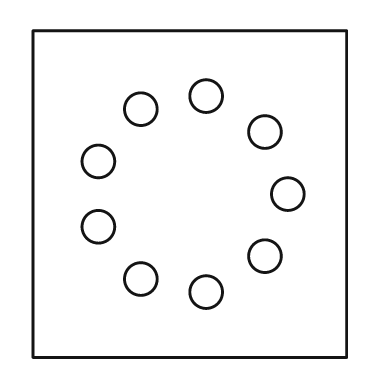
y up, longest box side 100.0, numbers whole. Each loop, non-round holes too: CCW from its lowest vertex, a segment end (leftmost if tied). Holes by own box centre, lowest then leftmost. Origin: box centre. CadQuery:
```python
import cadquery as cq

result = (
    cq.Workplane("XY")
    .moveTo(-48.0, -50.0)
    .lineTo(48.0, -50.0)
    .lineTo(48.0, 50.0)
    .lineTo(-48.0, 50.0)
    .close()
    .moveTo(5.0, -30.0)
    .circle(5.0)
    .moveTo(-15.0, -26.0)
    .circle(5.0)
    .moveTo(23.0, -19.0)
    .circle(5.0)
    .moveTo(-28.0, -10.0)
    .circle(5.0)
    .moveTo(30.0, 0.0)
    .circle(5.0)
    .moveTo(-28.0, 10.0)
    .circle(5.0)
    .moveTo(23.0, 19.0)
    .circle(5.0)
    .moveTo(-15.0, 26.0)
    .circle(5.0)
    .moveTo(5.0, 30.0)
    .circle(5.0)
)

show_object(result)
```